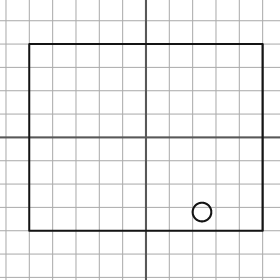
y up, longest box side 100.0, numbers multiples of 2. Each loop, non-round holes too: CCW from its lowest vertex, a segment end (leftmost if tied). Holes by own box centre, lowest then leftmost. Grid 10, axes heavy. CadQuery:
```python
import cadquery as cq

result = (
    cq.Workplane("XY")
    .moveTo(-50.0, -40.0)
    .lineTo(50.0, -40.0)
    .lineTo(50.0, 40.0)
    .lineTo(-50.0, 40.0)
    .close()
    .moveTo(24.0, -32.0)
    .circle(4.0)
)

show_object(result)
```